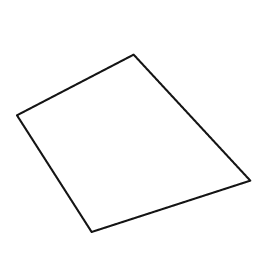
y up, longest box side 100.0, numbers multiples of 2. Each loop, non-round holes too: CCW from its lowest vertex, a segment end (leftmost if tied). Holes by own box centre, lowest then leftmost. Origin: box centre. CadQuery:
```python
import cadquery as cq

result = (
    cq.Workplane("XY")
    .moveTo(-18.0, -38.0)
    .lineTo(50.0, -16.0)
    .lineTo(0.0, 38.0)
    .lineTo(-50.0, 12.0)
    .close()
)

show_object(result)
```